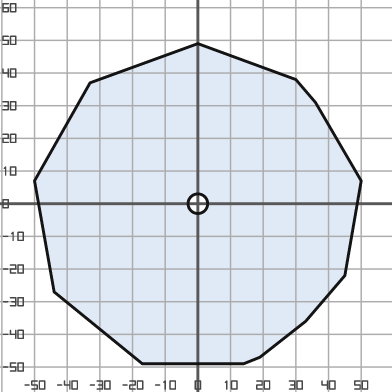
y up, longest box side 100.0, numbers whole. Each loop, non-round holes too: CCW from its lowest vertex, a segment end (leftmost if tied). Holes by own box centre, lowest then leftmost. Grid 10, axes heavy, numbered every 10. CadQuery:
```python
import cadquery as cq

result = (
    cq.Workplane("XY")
    .moveTo(-17.0, -49.0)
    .lineTo(14.0, -49.0)
    .lineTo(19.0, -47.0)
    .lineTo(33.0, -36.0)
    .lineTo(45.0, -22.0)
    .lineTo(50.0, 7.0)
    .lineTo(36.0, 31.0)
    .lineTo(30.0, 38.0)
    .lineTo(0.0, 49.0)
    .lineTo(-33.0, 37.0)
    .lineTo(-50.0, 7.0)
    .lineTo(-44.0, -27.0)
    .close()
    .moveTo(0.0, 0.0)
    .circle(3.0)
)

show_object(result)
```